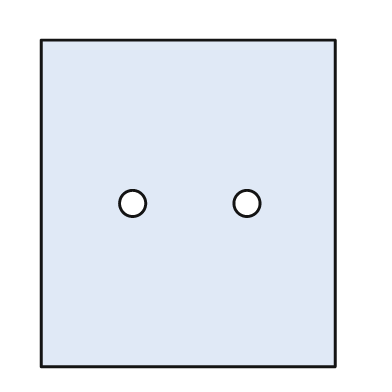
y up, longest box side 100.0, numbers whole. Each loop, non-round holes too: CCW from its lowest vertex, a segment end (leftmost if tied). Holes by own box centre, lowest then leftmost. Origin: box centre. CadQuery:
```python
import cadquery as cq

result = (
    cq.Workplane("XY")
    .moveTo(-45.0, -50.0)
    .lineTo(45.0, -50.0)
    .lineTo(45.0, 50.0)
    .lineTo(-45.0, 50.0)
    .close()
    .moveTo(-17.0, 0.0)
    .circle(4.0)
    .moveTo(18.0, 0.0)
    .circle(4.0)
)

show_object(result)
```